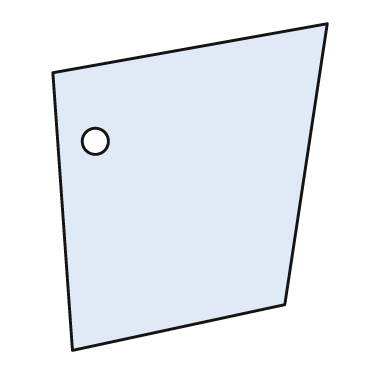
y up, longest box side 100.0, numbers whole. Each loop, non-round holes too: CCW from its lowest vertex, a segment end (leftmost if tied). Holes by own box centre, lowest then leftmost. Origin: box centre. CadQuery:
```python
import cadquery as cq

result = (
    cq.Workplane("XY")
    .moveTo(-36.0, -50.0)
    .lineTo(29.0, -36.0)
    .lineTo(42.0, 50.0)
    .lineTo(-42.0, 35.0)
    .close()
    .moveTo(-29.0, 14.0)
    .circle(4.0)
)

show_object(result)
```